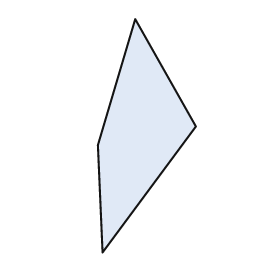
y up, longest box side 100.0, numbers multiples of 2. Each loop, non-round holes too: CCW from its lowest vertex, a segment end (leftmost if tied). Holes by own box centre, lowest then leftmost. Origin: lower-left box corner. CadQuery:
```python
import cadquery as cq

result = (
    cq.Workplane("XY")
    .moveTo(2.0, 0.0)
    .lineTo(42.0, 54.0)
    .lineTo(16.0, 100.0)
    .lineTo(0.0, 46.0)
    .close()
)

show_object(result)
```